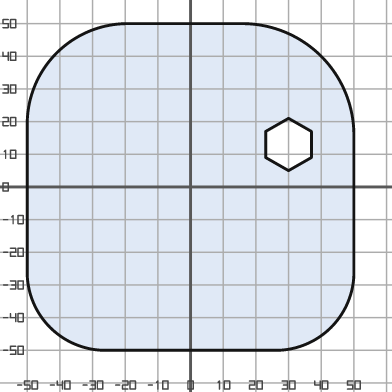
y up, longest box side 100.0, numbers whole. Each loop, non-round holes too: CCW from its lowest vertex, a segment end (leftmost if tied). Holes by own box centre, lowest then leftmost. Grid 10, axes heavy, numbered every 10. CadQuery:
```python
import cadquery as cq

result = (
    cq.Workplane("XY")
    .moveTo(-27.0, -50.0)
    .lineTo(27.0, -50.0)
    .threePointArc((43.0, -43.0), (50.0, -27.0))
    .lineTo(50.0, 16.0)
    .threePointArc((40.0, 40.0), (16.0, 50.0))
    .lineTo(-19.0, 50.0)
    .threePointArc((-41.0, 41.0), (-50.0, 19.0))
    .lineTo(-50.0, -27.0)
    .threePointArc((-43.0, -43.0), (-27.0, -50.0))
    .close()
    .moveTo(30.0, 5.0)
    .lineTo(37.0, 9.0)
    .lineTo(37.0, 17.0)
    .lineTo(30.0, 21.0)
    .lineTo(23.0, 17.0)
    .lineTo(23.0, 9.0)
    .close()
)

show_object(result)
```